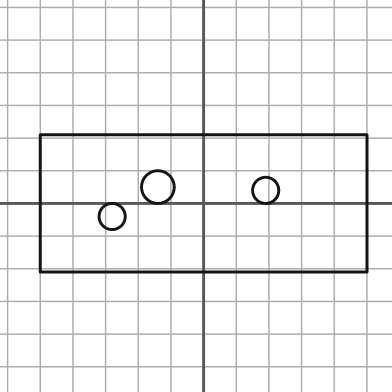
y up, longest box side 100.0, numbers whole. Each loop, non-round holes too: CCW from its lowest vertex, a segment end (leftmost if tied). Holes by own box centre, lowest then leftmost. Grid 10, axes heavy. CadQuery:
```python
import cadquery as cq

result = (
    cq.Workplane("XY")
    .moveTo(-50.0, -21.0)
    .lineTo(50.0, -21.0)
    .lineTo(50.0, 21.0)
    .lineTo(-50.0, 21.0)
    .close()
    .moveTo(-28.0, -4.0)
    .circle(4.0)
    .moveTo(19.0, 4.0)
    .circle(4.0)
    .moveTo(-14.0, 5.0)
    .circle(5.0)
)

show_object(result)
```